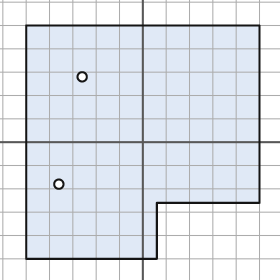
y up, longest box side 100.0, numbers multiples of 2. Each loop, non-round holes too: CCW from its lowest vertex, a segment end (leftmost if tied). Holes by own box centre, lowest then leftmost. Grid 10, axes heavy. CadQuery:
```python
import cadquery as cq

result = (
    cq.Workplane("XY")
    .moveTo(-50.0, -50.0)
    .lineTo(6.0, -50.0)
    .lineTo(6.0, -26.0)
    .lineTo(50.0, -26.0)
    .lineTo(50.0, 50.0)
    .lineTo(-50.0, 50.0)
    .close()
    .moveTo(-36.0, -18.0)
    .circle(2.0)
    .moveTo(-26.0, 28.0)
    .circle(2.0)
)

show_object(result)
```